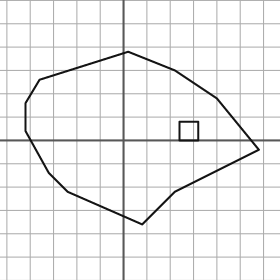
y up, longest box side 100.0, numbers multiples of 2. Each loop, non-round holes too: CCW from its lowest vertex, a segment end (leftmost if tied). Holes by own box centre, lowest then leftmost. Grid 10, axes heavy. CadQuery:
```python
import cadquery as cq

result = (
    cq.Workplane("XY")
    .moveTo(8.0, -36.0)
    .lineTo(22.0, -22.0)
    .lineTo(58.0, -4.0)
    .lineTo(40.0, 18.0)
    .lineTo(22.0, 30.0)
    .lineTo(2.0, 38.0)
    .lineTo(-36.0, 26.0)
    .lineTo(-42.0, 16.0)
    .lineTo(-42.0, 4.0)
    .lineTo(-32.0, -14.0)
    .lineTo(-24.0, -22.0)
    .close()
    .moveTo(24.0, 0.0)
    .lineTo(32.0, 0.0)
    .lineTo(32.0, 8.0)
    .lineTo(24.0, 8.0)
    .close()
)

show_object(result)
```